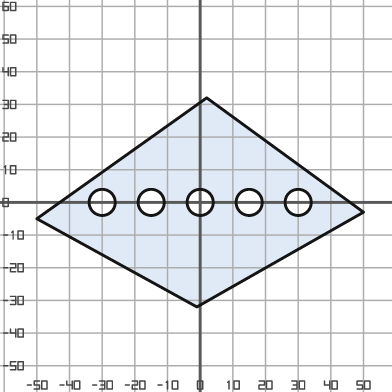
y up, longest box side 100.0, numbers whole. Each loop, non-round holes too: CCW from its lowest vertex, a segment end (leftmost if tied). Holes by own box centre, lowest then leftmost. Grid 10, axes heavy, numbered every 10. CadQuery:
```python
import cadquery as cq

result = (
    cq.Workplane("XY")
    .moveTo(-1.0, -32.0)
    .lineTo(50.0, -3.0)
    .lineTo(2.0, 32.0)
    .lineTo(-50.0, -5.0)
    .close()
    .moveTo(-30.0, 0.0)
    .circle(4.0)
    .moveTo(-15.0, 0.0)
    .circle(4.0)
    .moveTo(0.0, 0.0)
    .circle(4.0)
    .moveTo(15.0, 0.0)
    .circle(4.0)
    .moveTo(30.0, 0.0)
    .circle(4.0)
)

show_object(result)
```